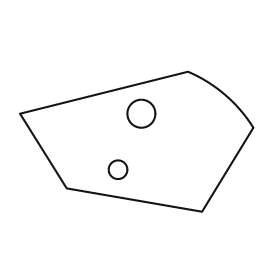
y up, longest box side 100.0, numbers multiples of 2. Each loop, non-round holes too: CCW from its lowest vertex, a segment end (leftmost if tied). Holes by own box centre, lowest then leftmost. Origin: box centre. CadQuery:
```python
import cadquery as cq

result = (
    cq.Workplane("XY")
    .moveTo(28.0, -30.0)
    .lineTo(50.0, 6.0)
    .threePointArc((38.0, 20.0), (22.0, 30.0))
    .lineTo(-50.0, 12.0)
    .lineTo(-30.0, -20.0)
    .close()
    .moveTo(-8.0, -12.0)
    .circle(4.0)
    .moveTo(2.0, 12.0)
    .circle(6.0)
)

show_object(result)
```